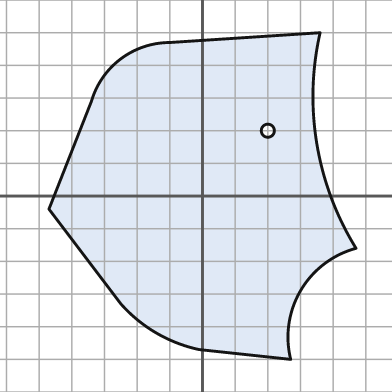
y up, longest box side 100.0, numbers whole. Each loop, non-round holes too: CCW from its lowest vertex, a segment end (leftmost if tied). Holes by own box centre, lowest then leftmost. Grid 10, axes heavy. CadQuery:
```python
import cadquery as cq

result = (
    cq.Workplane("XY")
    .moveTo(27.0, -50.0)
    .threePointArc((30.0, -29.0), (47.0, -16.0))
    .threePointArc((35.0, 16.0), (36.0, 50.0))
    .lineTo(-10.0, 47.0)
    .threePointArc((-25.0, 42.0), (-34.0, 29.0))
    .lineTo(-47.0, -4.0)
    .lineTo(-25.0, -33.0)
    .threePointArc((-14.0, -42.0), (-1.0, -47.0))
    .close()
    .moveTo(20.0, 20.0)
    .circle(2.0)
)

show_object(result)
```